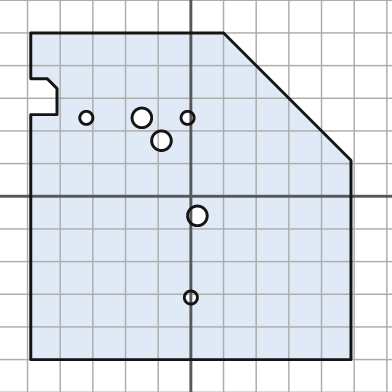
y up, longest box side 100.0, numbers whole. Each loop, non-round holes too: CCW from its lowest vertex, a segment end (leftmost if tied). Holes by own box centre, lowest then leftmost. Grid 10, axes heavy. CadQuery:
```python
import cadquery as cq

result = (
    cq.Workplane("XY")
    .moveTo(-49.0, -50.0)
    .lineTo(49.0, -50.0)
    .lineTo(49.0, 11.0)
    .lineTo(10.0, 50.0)
    .lineTo(-49.0, 50.0)
    .lineTo(-49.0, 36.0)
    .lineTo(-44.0, 36.0)
    .lineTo(-41.0, 33.0)
    .lineTo(-41.0, 25.0)
    .lineTo(-49.0, 25.0)
    .close()
    .moveTo(0.0, -31.0)
    .circle(2.0)
    .moveTo(2.0, -6.0)
    .circle(3.0)
    .moveTo(-9.0, 17.0)
    .circle(3.0)
    .moveTo(-32.0, 24.0)
    .circle(2.0)
    .moveTo(-15.0, 24.0)
    .circle(3.0)
    .moveTo(-1.0, 24.0)
    .circle(2.0)
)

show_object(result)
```